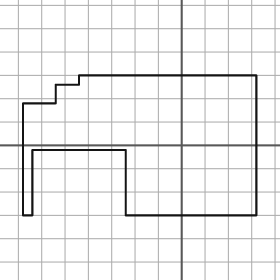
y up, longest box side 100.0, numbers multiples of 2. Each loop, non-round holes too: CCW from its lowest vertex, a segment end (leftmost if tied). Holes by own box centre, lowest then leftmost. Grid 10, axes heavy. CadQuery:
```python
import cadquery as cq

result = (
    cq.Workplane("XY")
    .moveTo(-68.0, -30.0)
    .lineTo(-64.0, -30.0)
    .lineTo(-64.0, -2.0)
    .lineTo(-24.0, -2.0)
    .lineTo(-24.0, -30.0)
    .lineTo(32.0, -30.0)
    .lineTo(32.0, 30.0)
    .lineTo(-44.0, 30.0)
    .lineTo(-44.0, 26.0)
    .lineTo(-54.0, 26.0)
    .lineTo(-54.0, 18.0)
    .lineTo(-68.0, 18.0)
    .close()
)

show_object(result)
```